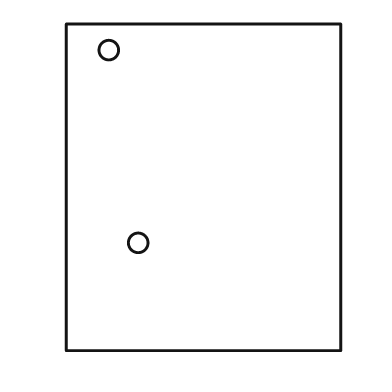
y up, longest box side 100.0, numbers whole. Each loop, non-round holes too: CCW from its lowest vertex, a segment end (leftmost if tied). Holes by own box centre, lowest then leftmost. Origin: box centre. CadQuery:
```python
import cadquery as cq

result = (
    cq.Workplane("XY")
    .moveTo(-42.0, -50.0)
    .lineTo(42.0, -50.0)
    .lineTo(42.0, 50.0)
    .lineTo(-42.0, 50.0)
    .close()
    .moveTo(-20.0, -17.0)
    .circle(3.0)
    .moveTo(-29.0, 42.0)
    .circle(3.0)
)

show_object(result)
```